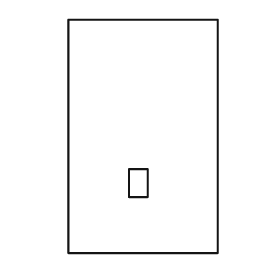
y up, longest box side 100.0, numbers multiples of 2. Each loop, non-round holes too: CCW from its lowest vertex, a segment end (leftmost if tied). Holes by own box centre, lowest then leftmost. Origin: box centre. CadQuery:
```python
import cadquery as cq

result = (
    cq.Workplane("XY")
    .moveTo(-32.0, -50.0)
    .lineTo(32.0, -50.0)
    .lineTo(32.0, 50.0)
    .lineTo(-32.0, 50.0)
    .close()
    .moveTo(-6.0, -26.0)
    .lineTo(2.0, -26.0)
    .lineTo(2.0, -14.0)
    .lineTo(-6.0, -14.0)
    .close()
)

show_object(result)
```